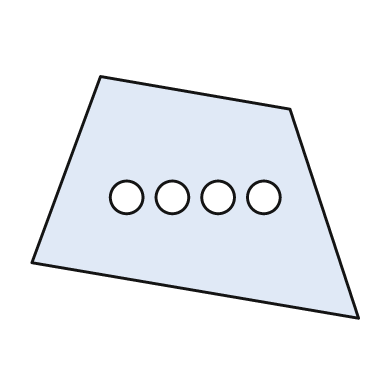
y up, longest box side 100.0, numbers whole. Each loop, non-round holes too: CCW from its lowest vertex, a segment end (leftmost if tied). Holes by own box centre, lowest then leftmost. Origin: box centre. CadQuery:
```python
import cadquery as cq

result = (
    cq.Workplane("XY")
    .moveTo(50.0, -37.0)
    .lineTo(29.0, 27.0)
    .lineTo(-29.0, 37.0)
    .lineTo(-50.0, -20.0)
    .close()
    .moveTo(-21.0, 0.0)
    .circle(5.0)
    .moveTo(-7.0, 0.0)
    .circle(5.0)
    .moveTo(7.0, 0.0)
    .circle(5.0)
    .moveTo(21.0, 0.0)
    .circle(5.0)
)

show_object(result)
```